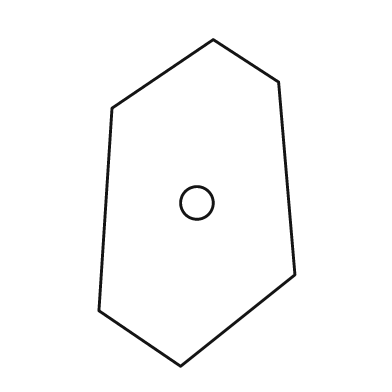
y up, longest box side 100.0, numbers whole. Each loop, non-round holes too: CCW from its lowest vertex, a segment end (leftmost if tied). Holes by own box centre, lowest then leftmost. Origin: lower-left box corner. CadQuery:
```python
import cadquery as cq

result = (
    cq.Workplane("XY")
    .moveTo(25.0, 0.0)
    .lineTo(60.0, 28.0)
    .lineTo(55.0, 87.0)
    .lineTo(35.0, 100.0)
    .lineTo(4.0, 79.0)
    .lineTo(0.0, 17.0)
    .close()
    .moveTo(30.0, 50.0)
    .circle(5.0)
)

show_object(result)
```